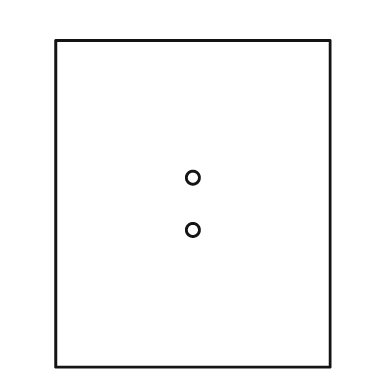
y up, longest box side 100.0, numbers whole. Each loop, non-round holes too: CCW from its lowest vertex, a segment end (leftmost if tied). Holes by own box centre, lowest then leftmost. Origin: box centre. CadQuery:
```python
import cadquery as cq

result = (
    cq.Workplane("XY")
    .moveTo(-42.0, -50.0)
    .lineTo(42.0, -50.0)
    .lineTo(42.0, 50.0)
    .lineTo(-42.0, 50.0)
    .close()
    .moveTo(0.0, -8.0)
    .circle(2.0)
    .moveTo(0.0, 8.0)
    .circle(2.0)
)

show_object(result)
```